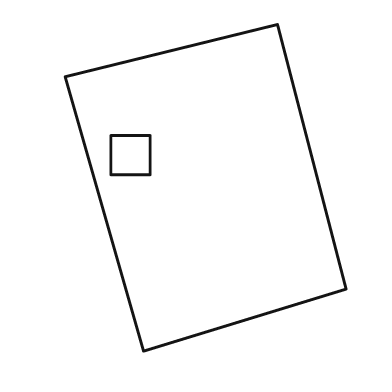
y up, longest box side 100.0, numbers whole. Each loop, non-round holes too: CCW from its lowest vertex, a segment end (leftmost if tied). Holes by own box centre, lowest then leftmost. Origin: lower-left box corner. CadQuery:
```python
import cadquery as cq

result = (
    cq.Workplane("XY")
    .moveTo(24.0, 0.0)
    .lineTo(86.0, 19.0)
    .lineTo(65.0, 100.0)
    .lineTo(0.0, 84.0)
    .close()
    .moveTo(14.0, 54.0)
    .lineTo(26.0, 54.0)
    .lineTo(26.0, 66.0)
    .lineTo(14.0, 66.0)
    .close()
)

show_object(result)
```